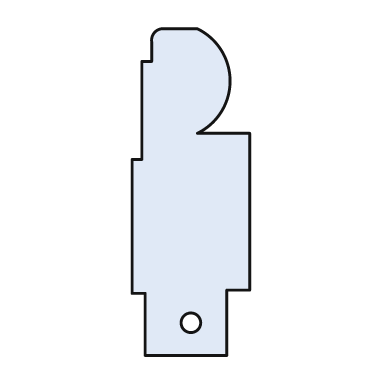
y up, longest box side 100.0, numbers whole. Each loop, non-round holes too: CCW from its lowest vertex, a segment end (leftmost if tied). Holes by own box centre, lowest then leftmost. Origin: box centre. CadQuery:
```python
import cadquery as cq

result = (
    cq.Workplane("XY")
    .moveTo(-14.0, -50.0)
    .lineTo(11.0, -50.0)
    .lineTo(11.0, -30.0)
    .lineTo(18.0, -30.0)
    .lineTo(18.0, 18.0)
    .lineTo(2.0, 18.0)
    .threePointArc((12.0, 34.0), (2.0, 50.0))
    .lineTo(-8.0, 50.0)
    .threePointArc((-11.0, 49.0), (-12.0, 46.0))
    .lineTo(-12.0, 40.0)
    .lineTo(-15.0, 40.0)
    .lineTo(-15.0, 10.0)
    .lineTo(-18.0, 10.0)
    .lineTo(-18.0, -31.0)
    .lineTo(-14.0, -31.0)
    .close()
    .moveTo(0.0, -40.0)
    .circle(3.0)
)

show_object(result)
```